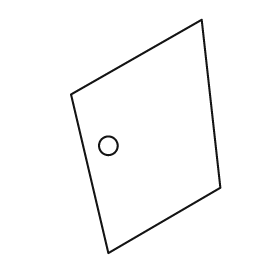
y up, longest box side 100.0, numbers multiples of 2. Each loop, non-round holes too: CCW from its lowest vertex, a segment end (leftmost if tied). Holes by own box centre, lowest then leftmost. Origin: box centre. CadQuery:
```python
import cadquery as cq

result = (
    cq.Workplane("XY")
    .moveTo(-16.0, -50.0)
    .lineTo(32.0, -22.0)
    .lineTo(24.0, 50.0)
    .lineTo(-32.0, 18.0)
    .close()
    .moveTo(-16.0, -4.0)
    .circle(4.0)
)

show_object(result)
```